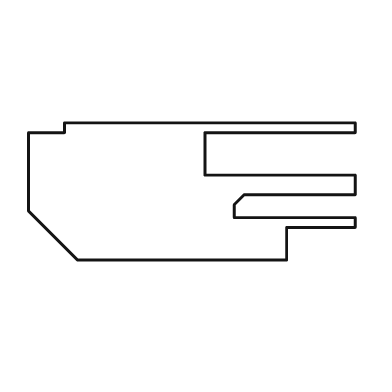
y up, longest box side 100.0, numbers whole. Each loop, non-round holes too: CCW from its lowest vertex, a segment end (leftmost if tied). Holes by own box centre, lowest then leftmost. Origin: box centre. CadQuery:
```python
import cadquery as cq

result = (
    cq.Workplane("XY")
    .moveTo(-35.0, -21.0)
    .lineTo(29.0, -21.0)
    .lineTo(29.0, -11.0)
    .lineTo(50.0, -11.0)
    .lineTo(50.0, -8.0)
    .lineTo(13.0, -8.0)
    .lineTo(13.0, -4.0)
    .lineTo(16.0, -1.0)
    .lineTo(50.0, -1.0)
    .lineTo(50.0, 5.0)
    .lineTo(4.0, 5.0)
    .lineTo(4.0, 18.0)
    .lineTo(50.0, 18.0)
    .lineTo(50.0, 21.0)
    .lineTo(-39.0, 21.0)
    .lineTo(-39.0, 18.0)
    .lineTo(-50.0, 18.0)
    .lineTo(-50.0, -6.0)
    .close()
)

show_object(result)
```